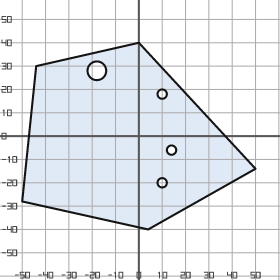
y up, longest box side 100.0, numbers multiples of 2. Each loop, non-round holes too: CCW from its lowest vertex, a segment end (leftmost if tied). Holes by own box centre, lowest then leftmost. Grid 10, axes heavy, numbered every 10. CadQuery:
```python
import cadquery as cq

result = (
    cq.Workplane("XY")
    .moveTo(4.0, -40.0)
    .lineTo(50.0, -14.0)
    .lineTo(0.0, 40.0)
    .lineTo(-44.0, 30.0)
    .lineTo(-50.0, -28.0)
    .close()
    .moveTo(10.0, -20.0)
    .circle(2.0)
    .moveTo(14.0, -6.0)
    .circle(2.0)
    .moveTo(10.0, 18.0)
    .circle(2.0)
    .moveTo(-18.0, 28.0)
    .circle(4.0)
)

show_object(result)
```